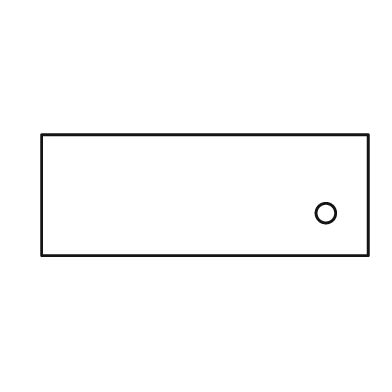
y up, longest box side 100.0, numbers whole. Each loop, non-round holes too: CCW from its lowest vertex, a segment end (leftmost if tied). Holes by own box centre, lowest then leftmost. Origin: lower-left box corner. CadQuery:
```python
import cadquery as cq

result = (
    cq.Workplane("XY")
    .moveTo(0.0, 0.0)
    .lineTo(100.0, 0.0)
    .lineTo(100.0, 37.0)
    .lineTo(0.0, 37.0)
    .close()
    .moveTo(87.0, 13.0)
    .circle(3.0)
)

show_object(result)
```